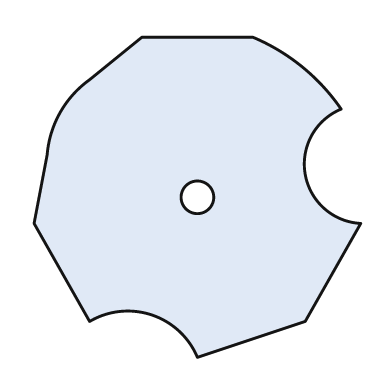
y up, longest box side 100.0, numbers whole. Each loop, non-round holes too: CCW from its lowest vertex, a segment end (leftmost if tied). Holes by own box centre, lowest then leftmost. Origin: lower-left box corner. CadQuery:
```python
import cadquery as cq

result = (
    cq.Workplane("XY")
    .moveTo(50.0, 0.0)
    .lineTo(83.0, 11.0)
    .lineTo(100.0, 41.0)
    .threePointArc((83.0, 56.0), (94.0, 76.0))
    .threePointArc((82.0, 89.0), (67.0, 98.0))
    .lineTo(33.0, 98.0)
    .lineTo(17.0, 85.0)
    .threePointArc((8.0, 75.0), (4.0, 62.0))
    .lineTo(0.0, 41.0)
    .lineTo(17.0, 11.0)
    .threePointArc((36.0, 13.0), (50.0, 0.0))
    .close()
    .moveTo(50.0, 49.0)
    .circle(5.0)
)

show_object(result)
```